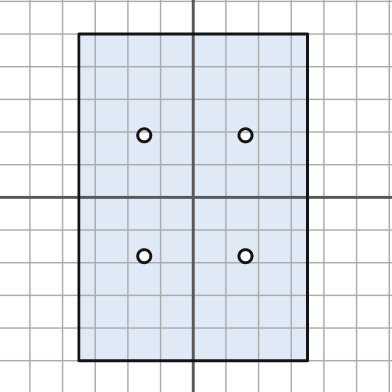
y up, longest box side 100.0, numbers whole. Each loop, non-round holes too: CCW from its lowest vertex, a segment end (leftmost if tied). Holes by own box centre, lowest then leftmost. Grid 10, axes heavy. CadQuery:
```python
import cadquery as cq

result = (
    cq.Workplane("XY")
    .moveTo(-35.0, -50.0)
    .lineTo(35.0, -50.0)
    .lineTo(35.0, 50.0)
    .lineTo(-35.0, 50.0)
    .close()
    .moveTo(-15.0, -18.0)
    .circle(2.0)
    .moveTo(16.0, -18.0)
    .circle(2.0)
    .moveTo(-15.0, 19.0)
    .circle(2.0)
    .moveTo(16.0, 19.0)
    .circle(2.0)
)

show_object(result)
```